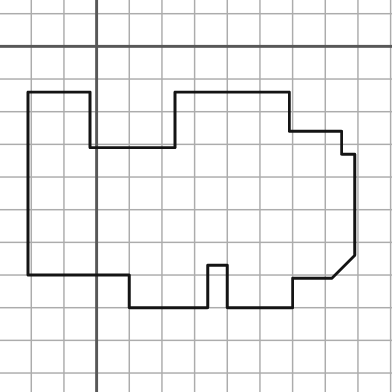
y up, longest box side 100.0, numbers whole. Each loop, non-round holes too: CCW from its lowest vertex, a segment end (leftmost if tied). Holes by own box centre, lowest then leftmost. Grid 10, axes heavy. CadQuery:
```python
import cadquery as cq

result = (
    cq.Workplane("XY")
    .moveTo(10.0, -80.0)
    .lineTo(34.0, -80.0)
    .lineTo(34.0, -67.0)
    .lineTo(40.0, -67.0)
    .lineTo(40.0, -80.0)
    .lineTo(60.0, -80.0)
    .lineTo(60.0, -71.0)
    .lineTo(72.0, -71.0)
    .lineTo(79.0, -64.0)
    .lineTo(79.0, -33.0)
    .lineTo(75.0, -33.0)
    .lineTo(75.0, -26.0)
    .lineTo(59.0, -26.0)
    .lineTo(59.0, -14.0)
    .lineTo(24.0, -14.0)
    .lineTo(24.0, -31.0)
    .lineTo(-2.0, -31.0)
    .lineTo(-2.0, -14.0)
    .lineTo(-21.0, -14.0)
    .lineTo(-21.0, -70.0)
    .lineTo(10.0, -70.0)
    .close()
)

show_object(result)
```